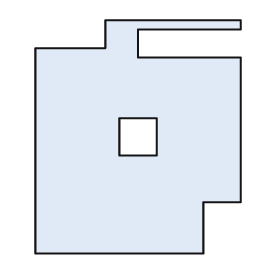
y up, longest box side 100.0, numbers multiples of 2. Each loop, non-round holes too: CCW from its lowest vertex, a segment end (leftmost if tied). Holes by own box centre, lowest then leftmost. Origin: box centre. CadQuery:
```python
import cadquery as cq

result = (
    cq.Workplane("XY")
    .moveTo(-44.0, -50.0)
    .lineTo(28.0, -50.0)
    .lineTo(28.0, -28.0)
    .lineTo(44.0, -28.0)
    .lineTo(44.0, 34.0)
    .lineTo(0.0, 34.0)
    .lineTo(0.0, 46.0)
    .lineTo(44.0, 46.0)
    .lineTo(44.0, 50.0)
    .lineTo(-14.0, 50.0)
    .lineTo(-14.0, 38.0)
    .lineTo(-44.0, 38.0)
    .close()
    .moveTo(-8.0, -8.0)
    .lineTo(8.0, -8.0)
    .lineTo(8.0, 8.0)
    .lineTo(-8.0, 8.0)
    .close()
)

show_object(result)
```